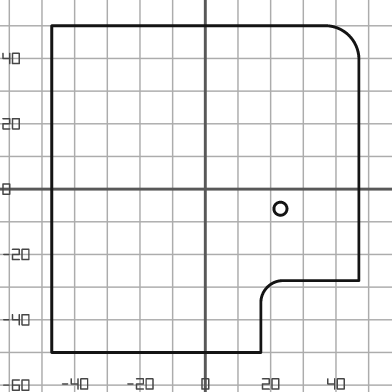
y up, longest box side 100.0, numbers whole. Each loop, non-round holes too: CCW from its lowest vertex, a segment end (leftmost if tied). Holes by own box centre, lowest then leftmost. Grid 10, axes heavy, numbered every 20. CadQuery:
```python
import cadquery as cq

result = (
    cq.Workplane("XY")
    .moveTo(-47.0, -50.0)
    .lineTo(17.0, -50.0)
    .lineTo(17.0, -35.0)
    .threePointArc((19.0, -30.0), (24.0, -28.0))
    .lineTo(47.0, -28.0)
    .lineTo(47.0, 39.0)
    .threePointArc((44.0, 47.0), (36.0, 50.0))
    .lineTo(-47.0, 50.0)
    .close()
    .moveTo(23.0, -6.0)
    .circle(2.0)
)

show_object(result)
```